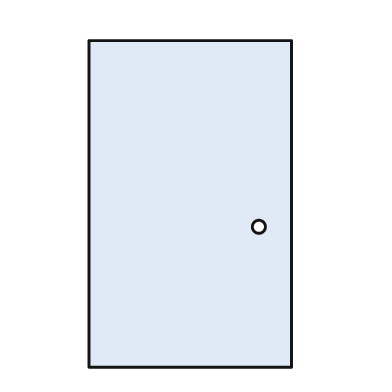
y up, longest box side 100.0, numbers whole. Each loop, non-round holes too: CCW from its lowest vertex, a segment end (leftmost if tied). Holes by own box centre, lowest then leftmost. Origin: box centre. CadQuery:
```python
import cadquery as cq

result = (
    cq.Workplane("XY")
    .moveTo(-31.0, -50.0)
    .lineTo(31.0, -50.0)
    .lineTo(31.0, 50.0)
    .lineTo(-31.0, 50.0)
    .close()
    .moveTo(21.0, -7.0)
    .circle(2.0)
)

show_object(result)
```